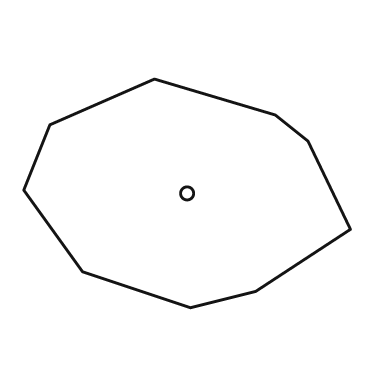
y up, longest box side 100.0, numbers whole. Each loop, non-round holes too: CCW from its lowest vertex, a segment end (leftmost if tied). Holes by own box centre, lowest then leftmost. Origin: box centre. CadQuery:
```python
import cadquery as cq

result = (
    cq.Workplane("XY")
    .moveTo(1.0, -35.0)
    .lineTo(21.0, -30.0)
    .lineTo(50.0, -11.0)
    .lineTo(37.0, 16.0)
    .lineTo(27.0, 24.0)
    .lineTo(-10.0, 35.0)
    .lineTo(-42.0, 21.0)
    .lineTo(-50.0, 1.0)
    .lineTo(-32.0, -24.0)
    .close()
    .moveTo(0.0, 0.0)
    .circle(2.0)
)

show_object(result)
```